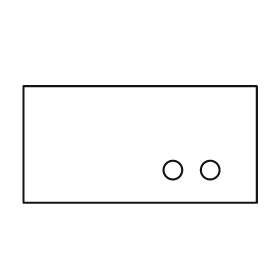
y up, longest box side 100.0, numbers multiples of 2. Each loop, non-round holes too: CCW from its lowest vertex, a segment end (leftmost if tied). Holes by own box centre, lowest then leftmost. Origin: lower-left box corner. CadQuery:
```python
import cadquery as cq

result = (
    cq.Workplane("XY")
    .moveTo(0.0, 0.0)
    .lineTo(100.0, 0.0)
    .lineTo(100.0, 50.0)
    .lineTo(0.0, 50.0)
    .close()
    .moveTo(64.0, 14.0)
    .circle(4.0)
    .moveTo(80.0, 14.0)
    .circle(4.0)
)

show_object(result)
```